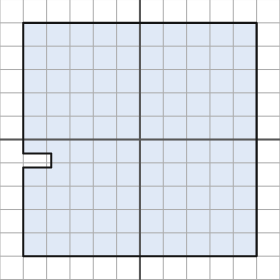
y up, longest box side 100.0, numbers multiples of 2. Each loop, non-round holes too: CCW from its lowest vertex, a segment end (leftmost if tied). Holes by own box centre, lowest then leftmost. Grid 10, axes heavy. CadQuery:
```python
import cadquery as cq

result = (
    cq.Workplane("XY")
    .moveTo(-50.0, -50.0)
    .lineTo(50.0, -50.0)
    .lineTo(50.0, 50.0)
    .lineTo(-50.0, 50.0)
    .lineTo(-50.0, -6.0)
    .lineTo(-38.0, -6.0)
    .lineTo(-38.0, -12.0)
    .lineTo(-50.0, -12.0)
    .close()
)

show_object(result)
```